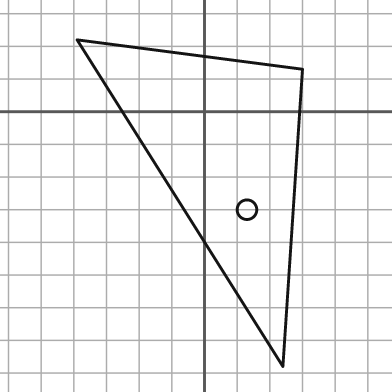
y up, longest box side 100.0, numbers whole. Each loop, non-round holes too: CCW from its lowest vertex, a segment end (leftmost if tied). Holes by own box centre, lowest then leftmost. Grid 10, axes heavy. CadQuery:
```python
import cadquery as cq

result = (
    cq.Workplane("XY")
    .moveTo(24.0, -78.0)
    .lineTo(30.0, 13.0)
    .lineTo(-39.0, 22.0)
    .close()
    .moveTo(13.0, -30.0)
    .circle(3.0)
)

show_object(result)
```